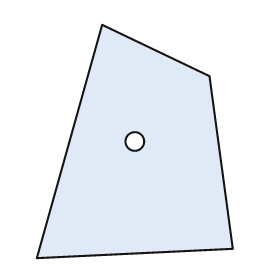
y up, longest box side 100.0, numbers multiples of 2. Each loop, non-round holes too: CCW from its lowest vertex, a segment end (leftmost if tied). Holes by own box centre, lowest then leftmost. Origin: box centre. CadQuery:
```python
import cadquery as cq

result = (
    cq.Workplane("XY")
    .moveTo(-42.0, -50.0)
    .lineTo(42.0, -46.0)
    .lineTo(32.0, 28.0)
    .lineTo(-14.0, 50.0)
    .close()
    .moveTo(0.0, 0.0)
    .circle(4.0)
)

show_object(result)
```